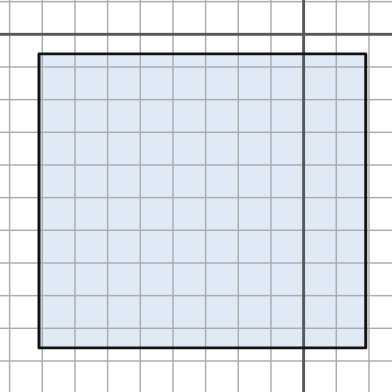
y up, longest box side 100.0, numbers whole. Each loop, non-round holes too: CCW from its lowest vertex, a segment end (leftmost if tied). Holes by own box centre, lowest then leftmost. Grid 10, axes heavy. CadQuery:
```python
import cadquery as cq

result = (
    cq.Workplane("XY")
    .moveTo(-81.0, -96.0)
    .lineTo(19.0, -96.0)
    .lineTo(19.0, -6.0)
    .lineTo(-81.0, -6.0)
    .close()
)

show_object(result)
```